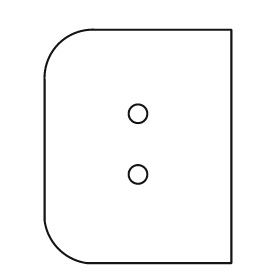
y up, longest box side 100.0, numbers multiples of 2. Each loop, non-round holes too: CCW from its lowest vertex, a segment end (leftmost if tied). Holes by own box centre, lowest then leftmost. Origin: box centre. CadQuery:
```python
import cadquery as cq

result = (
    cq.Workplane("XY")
    .moveTo(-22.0, -50.0)
    .lineTo(40.0, -50.0)
    .lineTo(40.0, 50.0)
    .lineTo(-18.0, 50.0)
    .threePointArc((-34.0, 44.0), (-40.0, 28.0))
    .lineTo(-40.0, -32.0)
    .threePointArc((-34.0, -44.0), (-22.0, -50.0))
    .close()
    .moveTo(0.0, -12.0)
    .circle(4.0)
    .moveTo(0.0, 14.0)
    .circle(4.0)
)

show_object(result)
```